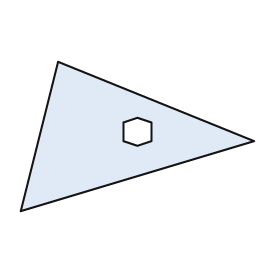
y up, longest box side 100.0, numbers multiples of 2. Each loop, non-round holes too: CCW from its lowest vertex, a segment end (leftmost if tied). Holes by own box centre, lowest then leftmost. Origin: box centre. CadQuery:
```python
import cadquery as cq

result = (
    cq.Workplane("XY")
    .moveTo(-50.0, -32.0)
    .lineTo(50.0, -2.0)
    .lineTo(-34.0, 32.0)
    .close()
    .moveTo(0.0, -4.0)
    .lineTo(6.0, -2.0)
    .lineTo(6.0, 6.0)
    .lineTo(0.0, 8.0)
    .lineTo(-6.0, 6.0)
    .lineTo(-6.0, -2.0)
    .close()
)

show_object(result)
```